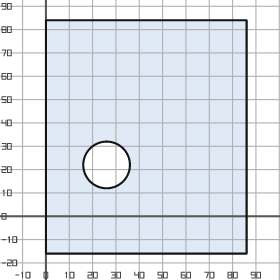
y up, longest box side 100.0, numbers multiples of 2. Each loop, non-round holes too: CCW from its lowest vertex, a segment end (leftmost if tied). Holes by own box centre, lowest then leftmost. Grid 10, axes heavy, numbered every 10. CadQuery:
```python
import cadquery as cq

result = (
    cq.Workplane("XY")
    .moveTo(0.0, -16.0)
    .lineTo(86.0, -16.0)
    .lineTo(86.0, 84.0)
    .lineTo(0.0, 84.0)
    .close()
    .moveTo(26.0, 22.0)
    .circle(10.0)
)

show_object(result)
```